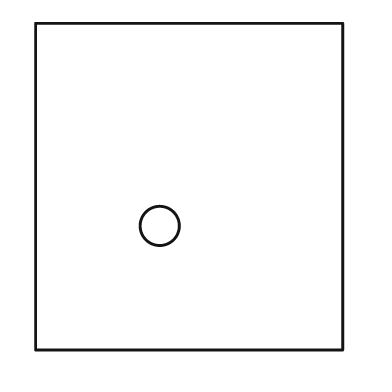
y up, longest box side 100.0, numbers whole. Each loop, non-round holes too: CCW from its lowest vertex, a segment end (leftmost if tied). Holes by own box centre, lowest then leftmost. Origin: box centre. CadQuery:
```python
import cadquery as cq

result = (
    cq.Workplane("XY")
    .moveTo(-47.0, -50.0)
    .lineTo(47.0, -50.0)
    .lineTo(47.0, 50.0)
    .lineTo(-47.0, 50.0)
    .close()
    .moveTo(-9.0, -12.0)
    .circle(6.0)
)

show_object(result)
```